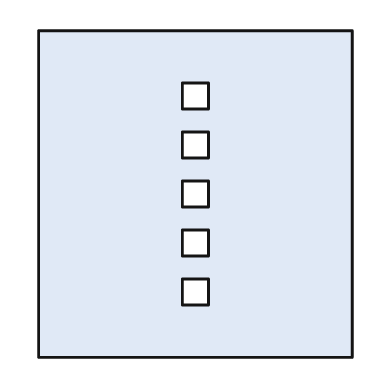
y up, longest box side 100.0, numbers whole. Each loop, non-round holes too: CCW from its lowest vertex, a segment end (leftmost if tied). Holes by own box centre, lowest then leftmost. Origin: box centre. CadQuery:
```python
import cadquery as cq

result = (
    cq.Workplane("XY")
    .moveTo(-48.0, -50.0)
    .lineTo(48.0, -50.0)
    .lineTo(48.0, 50.0)
    .lineTo(-48.0, 50.0)
    .close()
    .moveTo(-4.0, -34.0)
    .lineTo(4.0, -34.0)
    .lineTo(4.0, -26.0)
    .lineTo(-4.0, -26.0)
    .close()
    .moveTo(-4.0, -19.0)
    .lineTo(4.0, -19.0)
    .lineTo(4.0, -11.0)
    .lineTo(-4.0, -11.0)
    .close()
    .moveTo(-4.0, -4.0)
    .lineTo(4.0, -4.0)
    .lineTo(4.0, 4.0)
    .lineTo(-4.0, 4.0)
    .close()
    .moveTo(-4.0, 11.0)
    .lineTo(4.0, 11.0)
    .lineTo(4.0, 19.0)
    .lineTo(-4.0, 19.0)
    .close()
    .moveTo(-4.0, 26.0)
    .lineTo(4.0, 26.0)
    .lineTo(4.0, 34.0)
    .lineTo(-4.0, 34.0)
    .close()
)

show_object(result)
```